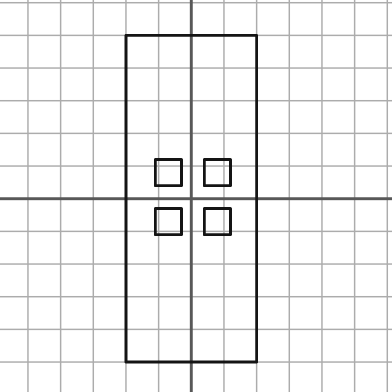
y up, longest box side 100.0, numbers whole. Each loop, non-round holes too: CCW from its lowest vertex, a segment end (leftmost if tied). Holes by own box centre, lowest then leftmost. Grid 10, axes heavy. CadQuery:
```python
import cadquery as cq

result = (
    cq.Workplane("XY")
    .moveTo(-20.0, -50.0)
    .lineTo(20.0, -50.0)
    .lineTo(20.0, 50.0)
    .lineTo(-20.0, 50.0)
    .close()
    .moveTo(-11.0, -11.0)
    .lineTo(-3.0, -11.0)
    .lineTo(-3.0, -3.0)
    .lineTo(-11.0, -3.0)
    .close()
    .moveTo(4.0, -11.0)
    .lineTo(12.0, -11.0)
    .lineTo(12.0, -3.0)
    .lineTo(4.0, -3.0)
    .close()
    .moveTo(-11.0, 4.0)
    .lineTo(-3.0, 4.0)
    .lineTo(-3.0, 12.0)
    .lineTo(-11.0, 12.0)
    .close()
    .moveTo(4.0, 4.0)
    .lineTo(12.0, 4.0)
    .lineTo(12.0, 12.0)
    .lineTo(4.0, 12.0)
    .close()
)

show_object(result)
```